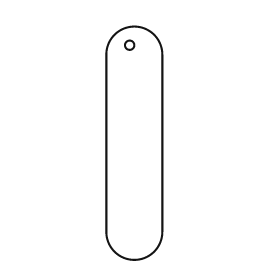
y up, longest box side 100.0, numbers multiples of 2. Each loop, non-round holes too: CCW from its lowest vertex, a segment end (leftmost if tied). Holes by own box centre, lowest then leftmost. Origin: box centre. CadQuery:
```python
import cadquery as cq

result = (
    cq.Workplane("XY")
    .moveTo(-12.0, -38.0)
    .threePointArc((0.0, -50.0), (12.0, -38.0))
    .lineTo(12.0, 38.0)
    .threePointArc((0.0, 50.0), (-12.0, 38.0))
    .close()
    .moveTo(-2.0, 42.0)
    .circle(2.0)
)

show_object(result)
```